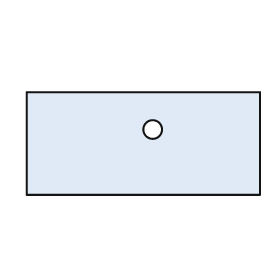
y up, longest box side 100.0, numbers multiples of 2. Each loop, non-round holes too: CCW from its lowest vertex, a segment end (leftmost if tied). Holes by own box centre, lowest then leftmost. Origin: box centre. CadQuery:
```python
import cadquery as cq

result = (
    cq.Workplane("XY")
    .moveTo(-50.0, -22.0)
    .lineTo(50.0, -22.0)
    .lineTo(50.0, 22.0)
    .lineTo(-50.0, 22.0)
    .close()
    .moveTo(4.0, 6.0)
    .circle(4.0)
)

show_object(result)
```